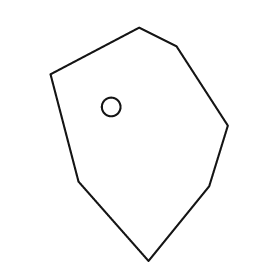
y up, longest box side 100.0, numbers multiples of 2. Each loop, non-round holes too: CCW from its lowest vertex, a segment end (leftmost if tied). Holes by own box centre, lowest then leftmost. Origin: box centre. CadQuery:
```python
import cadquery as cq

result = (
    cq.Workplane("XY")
    .moveTo(4.0, -50.0)
    .lineTo(30.0, -18.0)
    .lineTo(38.0, 8.0)
    .lineTo(16.0, 42.0)
    .lineTo(0.0, 50.0)
    .lineTo(-38.0, 30.0)
    .lineTo(-26.0, -16.0)
    .close()
    .moveTo(-12.0, 16.0)
    .circle(4.0)
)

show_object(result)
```